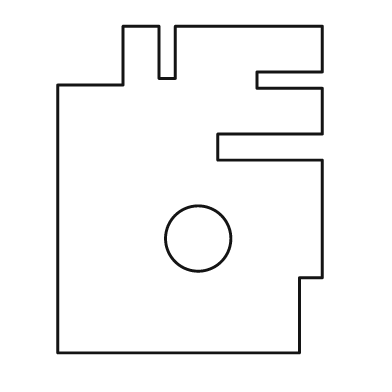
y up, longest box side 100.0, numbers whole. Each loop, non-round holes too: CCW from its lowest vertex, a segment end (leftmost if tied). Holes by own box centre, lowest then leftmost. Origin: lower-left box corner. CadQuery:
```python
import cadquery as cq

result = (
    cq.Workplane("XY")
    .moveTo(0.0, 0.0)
    .lineTo(74.0, 0.0)
    .lineTo(74.0, 23.0)
    .lineTo(81.0, 23.0)
    .lineTo(81.0, 59.0)
    .lineTo(49.0, 59.0)
    .lineTo(49.0, 67.0)
    .lineTo(81.0, 67.0)
    .lineTo(81.0, 81.0)
    .lineTo(61.0, 81.0)
    .lineTo(61.0, 86.0)
    .lineTo(81.0, 86.0)
    .lineTo(81.0, 100.0)
    .lineTo(36.0, 100.0)
    .lineTo(36.0, 84.0)
    .lineTo(31.0, 84.0)
    .lineTo(31.0, 100.0)
    .lineTo(20.0, 100.0)
    .lineTo(20.0, 82.0)
    .lineTo(0.0, 82.0)
    .close()
    .moveTo(43.0, 35.0)
    .circle(10.0)
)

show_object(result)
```